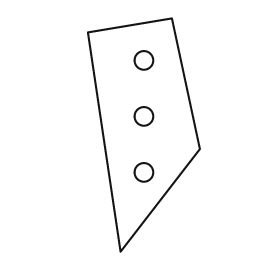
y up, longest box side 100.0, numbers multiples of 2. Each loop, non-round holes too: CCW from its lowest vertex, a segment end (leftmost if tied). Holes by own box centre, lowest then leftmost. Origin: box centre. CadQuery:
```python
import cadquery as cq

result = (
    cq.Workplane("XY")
    .moveTo(-10.0, -50.0)
    .lineTo(24.0, -6.0)
    .lineTo(12.0, 50.0)
    .lineTo(-24.0, 44.0)
    .close()
    .moveTo(0.0, -16.0)
    .circle(4.0)
    .moveTo(0.0, 8.0)
    .circle(4.0)
    .moveTo(0.0, 32.0)
    .circle(4.0)
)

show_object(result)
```